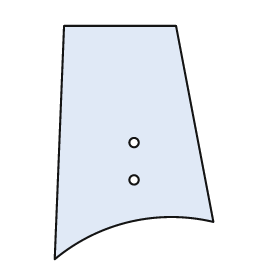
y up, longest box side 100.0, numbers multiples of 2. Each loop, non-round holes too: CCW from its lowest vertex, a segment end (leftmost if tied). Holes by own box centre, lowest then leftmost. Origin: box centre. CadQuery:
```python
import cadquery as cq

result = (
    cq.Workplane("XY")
    .moveTo(-34.0, -50.0)
    .threePointArc((-2.0, -34.0), (34.0, -34.0))
    .lineTo(18.0, 50.0)
    .lineTo(-30.0, 50.0)
    .close()
    .moveTo(0.0, -16.0)
    .circle(2.0)
    .moveTo(0.0, 0.0)
    .circle(2.0)
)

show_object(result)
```